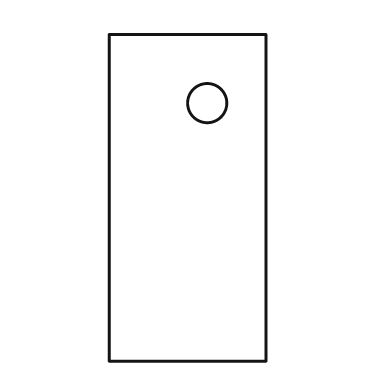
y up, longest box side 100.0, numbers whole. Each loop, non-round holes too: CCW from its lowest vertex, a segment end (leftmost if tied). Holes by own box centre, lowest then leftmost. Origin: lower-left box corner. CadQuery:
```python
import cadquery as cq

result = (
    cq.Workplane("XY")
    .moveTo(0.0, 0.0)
    .lineTo(48.0, 0.0)
    .lineTo(48.0, 100.0)
    .lineTo(0.0, 100.0)
    .close()
    .moveTo(30.0, 79.0)
    .circle(6.0)
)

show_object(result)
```